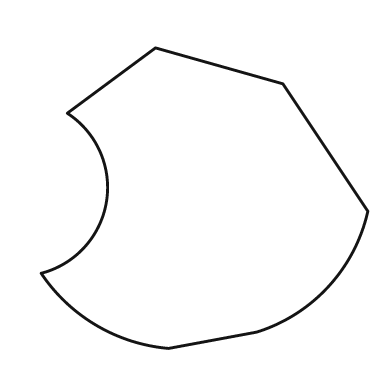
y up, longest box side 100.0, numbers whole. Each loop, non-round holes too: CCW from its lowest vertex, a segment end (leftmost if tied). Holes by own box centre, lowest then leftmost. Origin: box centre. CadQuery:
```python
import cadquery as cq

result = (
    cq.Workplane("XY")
    .moveTo(-11.0, -46.0)
    .lineTo(16.0, -41.0)
    .threePointArc((38.0, -27.0), (50.0, -4.0))
    .lineTo(24.0, 35.0)
    .lineTo(-15.0, 46.0)
    .lineTo(-42.0, 26.0)
    .threePointArc((-30.0, -1.0), (-50.0, -23.0))
    .threePointArc((-33.0, -39.0), (-11.0, -46.0))
    .close()
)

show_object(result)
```